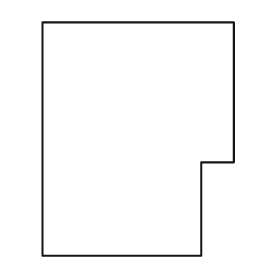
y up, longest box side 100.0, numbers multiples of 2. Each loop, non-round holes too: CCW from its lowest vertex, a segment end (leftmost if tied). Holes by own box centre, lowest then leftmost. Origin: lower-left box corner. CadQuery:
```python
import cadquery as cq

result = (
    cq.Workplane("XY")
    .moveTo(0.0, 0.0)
    .lineTo(68.0, 0.0)
    .lineTo(68.0, 40.0)
    .lineTo(82.0, 40.0)
    .lineTo(82.0, 100.0)
    .lineTo(0.0, 100.0)
    .close()
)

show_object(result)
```